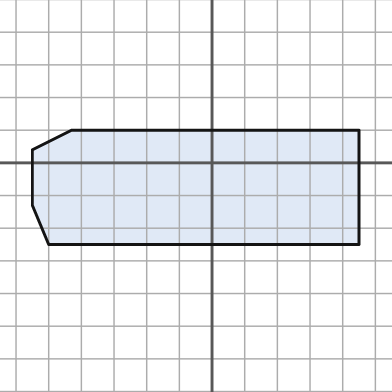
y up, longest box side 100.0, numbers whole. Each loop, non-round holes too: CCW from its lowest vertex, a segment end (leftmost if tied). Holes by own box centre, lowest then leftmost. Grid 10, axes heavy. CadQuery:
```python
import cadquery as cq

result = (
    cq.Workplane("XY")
    .moveTo(-50.0, -25.0)
    .lineTo(45.0, -25.0)
    .lineTo(45.0, 10.0)
    .lineTo(-43.0, 10.0)
    .lineTo(-55.0, 4.0)
    .lineTo(-55.0, -13.0)
    .close()
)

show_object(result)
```